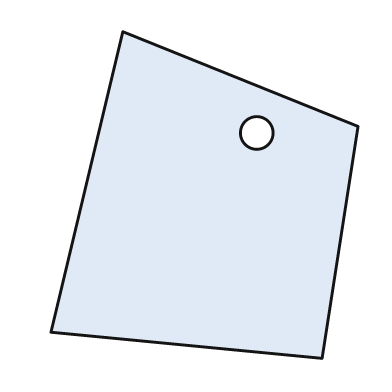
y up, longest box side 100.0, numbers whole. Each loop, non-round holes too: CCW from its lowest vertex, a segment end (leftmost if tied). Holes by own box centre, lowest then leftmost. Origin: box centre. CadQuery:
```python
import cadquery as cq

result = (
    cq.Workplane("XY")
    .moveTo(36.0, -50.0)
    .lineTo(47.0, 21.0)
    .lineTo(-25.0, 50.0)
    .lineTo(-47.0, -42.0)
    .close()
    .moveTo(16.0, 19.0)
    .circle(5.0)
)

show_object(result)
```